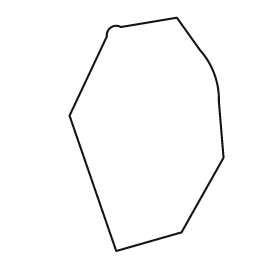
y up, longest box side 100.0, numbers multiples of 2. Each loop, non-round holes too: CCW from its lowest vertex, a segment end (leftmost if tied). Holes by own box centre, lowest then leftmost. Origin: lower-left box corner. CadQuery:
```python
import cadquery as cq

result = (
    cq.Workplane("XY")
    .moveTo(20.0, 0.0)
    .lineTo(48.0, 8.0)
    .lineTo(66.0, 40.0)
    .lineTo(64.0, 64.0)
    .threePointArc((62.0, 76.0), (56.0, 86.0))
    .lineTo(46.0, 100.0)
    .lineTo(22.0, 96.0)
    .threePointArc((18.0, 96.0), (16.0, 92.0))
    .lineTo(0.0, 58.0)
    .close()
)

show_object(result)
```